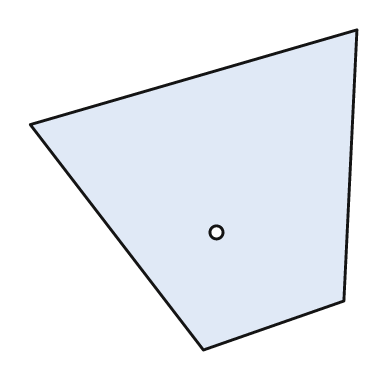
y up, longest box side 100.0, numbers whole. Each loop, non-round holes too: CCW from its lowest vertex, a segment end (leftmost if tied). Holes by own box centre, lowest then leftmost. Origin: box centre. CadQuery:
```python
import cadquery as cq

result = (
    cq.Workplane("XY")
    .moveTo(3.0, -49.0)
    .lineTo(46.0, -34.0)
    .lineTo(50.0, 49.0)
    .lineTo(-50.0, 20.0)
    .close()
    .moveTo(7.0, -13.0)
    .circle(2.0)
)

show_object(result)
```